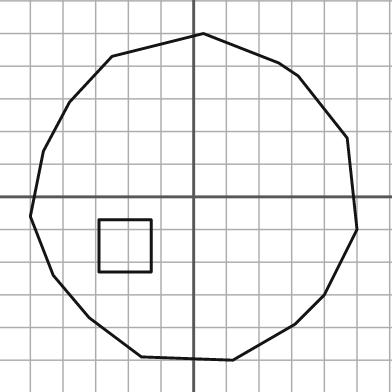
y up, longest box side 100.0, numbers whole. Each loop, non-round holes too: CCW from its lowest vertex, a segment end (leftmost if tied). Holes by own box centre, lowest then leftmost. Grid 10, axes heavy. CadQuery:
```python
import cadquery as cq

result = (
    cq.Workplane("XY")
    .moveTo(12.0, -50.0)
    .lineTo(31.0, -39.0)
    .lineTo(40.0, -30.0)
    .lineTo(50.0, -10.0)
    .lineTo(47.0, 18.0)
    .lineTo(32.0, 37.0)
    .lineTo(26.0, 41.0)
    .lineTo(3.0, 50.0)
    .lineTo(-25.0, 43.0)
    .lineTo(-38.0, 29.0)
    .lineTo(-46.0, 14.0)
    .lineTo(-50.0, -6.0)
    .lineTo(-43.0, -24.0)
    .lineTo(-32.0, -37.0)
    .lineTo(-16.0, -49.0)
    .close()
    .moveTo(-29.0, -23.0)
    .lineTo(-13.0, -23.0)
    .lineTo(-13.0, -7.0)
    .lineTo(-29.0, -7.0)
    .close()
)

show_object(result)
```